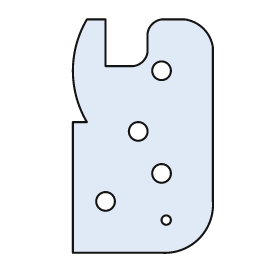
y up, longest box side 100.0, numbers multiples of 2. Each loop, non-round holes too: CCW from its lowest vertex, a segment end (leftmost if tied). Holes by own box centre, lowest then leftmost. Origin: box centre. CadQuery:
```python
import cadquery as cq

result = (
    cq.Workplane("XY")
    .moveTo(-30.0, -50.0)
    .lineTo(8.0, -50.0)
    .threePointArc((24.0, -44.0), (30.0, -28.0))
    .lineTo(30.0, 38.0)
    .threePointArc((26.0, 46.0), (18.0, 50.0))
    .lineTo(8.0, 50.0)
    .threePointArc((4.0, 48.0), (2.0, 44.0))
    .lineTo(2.0, 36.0)
    .threePointArc((0.0, 32.0), (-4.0, 30.0))
    .lineTo(-16.0, 30.0)
    .lineTo(-16.0, 50.0)
    .lineTo(-24.0, 50.0)
    .threePointArc((-30.0, 28.0), (-24.0, 6.0))
    .lineTo(-30.0, 6.0)
    .close()
    .moveTo(10.0, -36.0)
    .circle(2.0)
    .moveTo(-16.0, -28.0)
    .circle(4.0)
    .moveTo(8.0, -16.0)
    .circle(4.0)
    .moveTo(-2.0, 2.0)
    .circle(4.0)
    .moveTo(8.0, 28.0)
    .circle(4.0)
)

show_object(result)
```